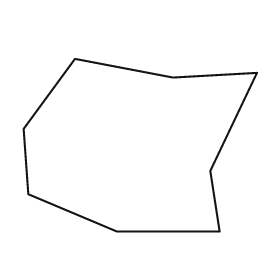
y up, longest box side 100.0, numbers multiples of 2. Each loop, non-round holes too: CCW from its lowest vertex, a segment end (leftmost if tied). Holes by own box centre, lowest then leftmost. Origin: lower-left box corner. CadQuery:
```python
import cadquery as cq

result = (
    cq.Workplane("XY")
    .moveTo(40.0, 0.0)
    .lineTo(84.0, 0.0)
    .lineTo(80.0, 26.0)
    .lineTo(100.0, 68.0)
    .lineTo(64.0, 66.0)
    .lineTo(22.0, 74.0)
    .lineTo(0.0, 44.0)
    .lineTo(2.0, 16.0)
    .close()
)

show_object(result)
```